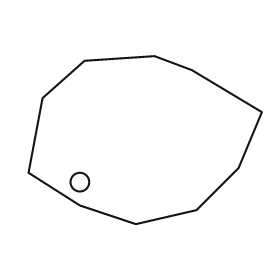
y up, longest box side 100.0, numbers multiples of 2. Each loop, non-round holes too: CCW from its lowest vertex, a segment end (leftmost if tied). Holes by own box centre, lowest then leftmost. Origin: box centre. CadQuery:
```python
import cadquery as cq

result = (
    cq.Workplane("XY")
    .moveTo(-4.0, -36.0)
    .lineTo(22.0, -30.0)
    .lineTo(40.0, -12.0)
    .lineTo(50.0, 12.0)
    .lineTo(20.0, 30.0)
    .lineTo(4.0, 36.0)
    .lineTo(-26.0, 34.0)
    .lineTo(-44.0, 18.0)
    .lineTo(-50.0, -14.0)
    .lineTo(-28.0, -28.0)
    .close()
    .moveTo(-28.0, -18.0)
    .circle(4.0)
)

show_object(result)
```